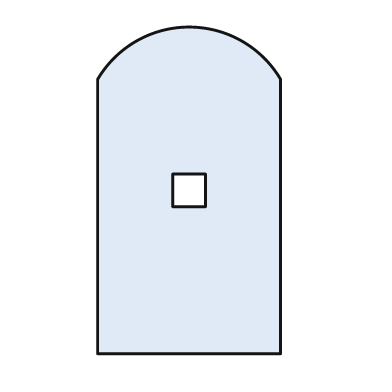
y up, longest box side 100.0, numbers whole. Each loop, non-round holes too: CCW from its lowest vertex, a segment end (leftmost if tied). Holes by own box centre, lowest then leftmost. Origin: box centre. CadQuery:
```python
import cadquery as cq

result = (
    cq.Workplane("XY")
    .moveTo(-28.0, -50.0)
    .lineTo(28.0, -50.0)
    .lineTo(28.0, 34.0)
    .threePointArc((0.0, 50.0), (-28.0, 34.0))
    .close()
    .moveTo(-5.0, -5.0)
    .lineTo(5.0, -5.0)
    .lineTo(5.0, 5.0)
    .lineTo(-5.0, 5.0)
    .close()
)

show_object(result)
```